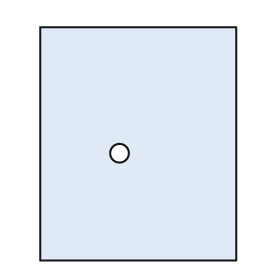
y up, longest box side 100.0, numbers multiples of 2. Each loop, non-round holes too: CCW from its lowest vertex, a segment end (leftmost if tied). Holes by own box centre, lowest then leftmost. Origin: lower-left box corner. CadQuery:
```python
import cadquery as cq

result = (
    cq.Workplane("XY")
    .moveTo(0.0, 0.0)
    .lineTo(84.0, 0.0)
    .lineTo(84.0, 100.0)
    .lineTo(0.0, 100.0)
    .close()
    .moveTo(34.0, 46.0)
    .circle(4.0)
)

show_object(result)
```